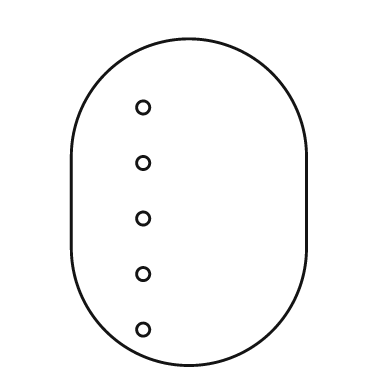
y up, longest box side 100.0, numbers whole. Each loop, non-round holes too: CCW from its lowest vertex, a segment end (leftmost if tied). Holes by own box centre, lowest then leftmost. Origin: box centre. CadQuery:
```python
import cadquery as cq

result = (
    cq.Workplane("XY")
    .moveTo(-36.0, -14.0)
    .threePointArc((0.0, -50.0), (36.0, -14.0))
    .lineTo(36.0, 14.0)
    .threePointArc((0.0, 50.0), (-36.0, 14.0))
    .close()
    .moveTo(-14.0, -39.0)
    .circle(2.0)
    .moveTo(-14.0, -22.0)
    .circle(2.0)
    .moveTo(-14.0, -5.0)
    .circle(2.0)
    .moveTo(-14.0, 12.0)
    .circle(2.0)
    .moveTo(-14.0, 29.0)
    .circle(2.0)
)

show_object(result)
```